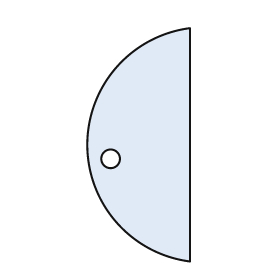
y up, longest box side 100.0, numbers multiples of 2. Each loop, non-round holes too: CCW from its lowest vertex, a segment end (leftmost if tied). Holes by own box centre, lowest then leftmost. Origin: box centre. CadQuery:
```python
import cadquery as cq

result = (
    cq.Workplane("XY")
    .moveTo(22.0, -50.0)
    .lineTo(22.0, 50.0)
    .threePointArc((-22.0, 0.0), (22.0, -50.0))
    .close()
    .moveTo(-12.0, -6.0)
    .circle(4.0)
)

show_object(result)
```